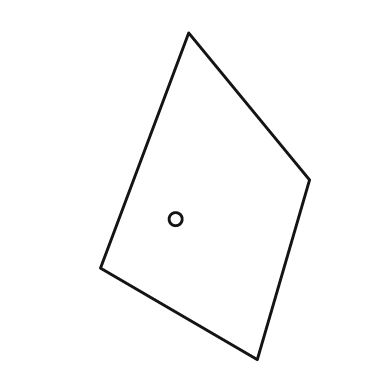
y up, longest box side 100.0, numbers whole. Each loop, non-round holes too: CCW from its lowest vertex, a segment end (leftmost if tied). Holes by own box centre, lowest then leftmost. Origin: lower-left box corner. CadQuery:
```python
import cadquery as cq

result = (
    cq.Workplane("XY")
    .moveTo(48.0, 0.0)
    .lineTo(64.0, 55.0)
    .lineTo(27.0, 100.0)
    .lineTo(0.0, 28.0)
    .close()
    .moveTo(23.0, 43.0)
    .circle(2.0)
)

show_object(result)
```